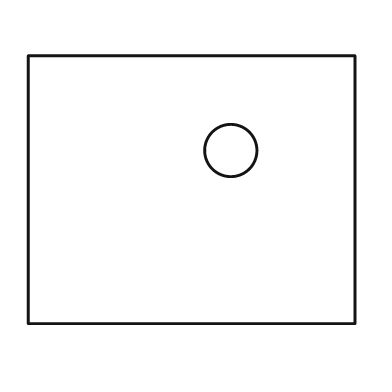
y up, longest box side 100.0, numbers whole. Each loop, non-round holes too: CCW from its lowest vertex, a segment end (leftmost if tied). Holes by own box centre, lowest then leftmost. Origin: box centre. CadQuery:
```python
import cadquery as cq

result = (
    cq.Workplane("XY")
    .moveTo(-50.0, -41.0)
    .lineTo(50.0, -41.0)
    .lineTo(50.0, 41.0)
    .lineTo(-50.0, 41.0)
    .close()
    .moveTo(12.0, 12.0)
    .circle(8.0)
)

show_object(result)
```